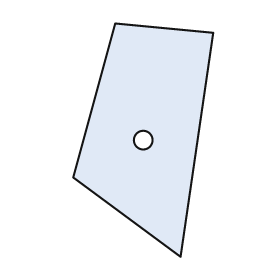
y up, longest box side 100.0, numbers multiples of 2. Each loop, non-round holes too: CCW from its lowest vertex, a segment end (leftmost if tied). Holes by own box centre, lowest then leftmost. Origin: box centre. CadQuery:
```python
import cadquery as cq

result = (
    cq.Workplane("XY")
    .moveTo(16.0, -50.0)
    .lineTo(30.0, 46.0)
    .lineTo(-12.0, 50.0)
    .lineTo(-30.0, -16.0)
    .close()
    .moveTo(0.0, 0.0)
    .circle(4.0)
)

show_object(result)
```